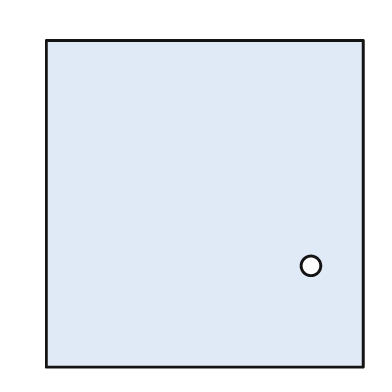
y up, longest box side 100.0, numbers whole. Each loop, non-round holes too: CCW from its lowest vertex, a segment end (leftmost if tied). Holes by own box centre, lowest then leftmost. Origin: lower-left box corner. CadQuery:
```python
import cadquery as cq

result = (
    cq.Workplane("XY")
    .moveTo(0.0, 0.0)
    .lineTo(97.0, 0.0)
    .lineTo(97.0, 100.0)
    .lineTo(0.0, 100.0)
    .close()
    .moveTo(81.0, 31.0)
    .circle(3.0)
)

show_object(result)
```